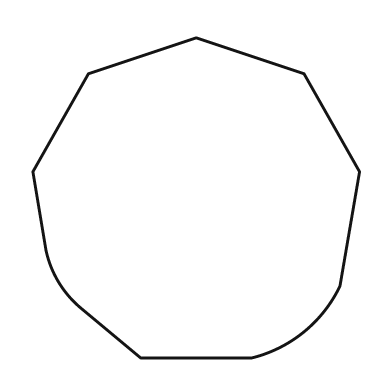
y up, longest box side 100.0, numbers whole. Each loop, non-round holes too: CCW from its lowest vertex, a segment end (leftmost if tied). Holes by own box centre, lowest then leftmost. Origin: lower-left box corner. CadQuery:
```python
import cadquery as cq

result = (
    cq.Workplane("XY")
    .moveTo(33.0, 0.0)
    .lineTo(67.0, 0.0)
    .threePointArc((83.0, 8.0), (94.0, 22.0))
    .lineTo(100.0, 57.0)
    .lineTo(83.0, 87.0)
    .lineTo(50.0, 98.0)
    .lineTo(17.0, 87.0)
    .lineTo(0.0, 57.0)
    .lineTo(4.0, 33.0)
    .threePointArc((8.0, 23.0), (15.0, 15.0))
    .close()
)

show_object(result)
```